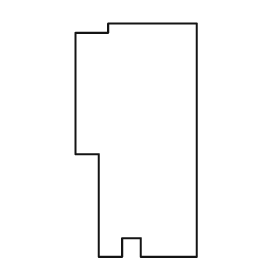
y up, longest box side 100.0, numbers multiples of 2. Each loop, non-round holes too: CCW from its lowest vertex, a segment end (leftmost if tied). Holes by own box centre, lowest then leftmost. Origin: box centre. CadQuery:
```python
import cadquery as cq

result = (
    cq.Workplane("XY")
    .moveTo(-16.0, -50.0)
    .lineTo(-6.0, -50.0)
    .lineTo(-6.0, -42.0)
    .lineTo(2.0, -42.0)
    .lineTo(2.0, -50.0)
    .lineTo(26.0, -50.0)
    .lineTo(26.0, 50.0)
    .lineTo(-12.0, 50.0)
    .lineTo(-12.0, 46.0)
    .lineTo(-26.0, 46.0)
    .lineTo(-26.0, -6.0)
    .lineTo(-16.0, -6.0)
    .close()
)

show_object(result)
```